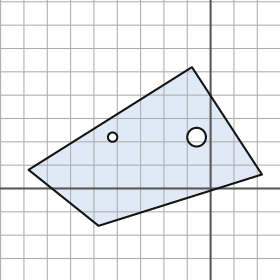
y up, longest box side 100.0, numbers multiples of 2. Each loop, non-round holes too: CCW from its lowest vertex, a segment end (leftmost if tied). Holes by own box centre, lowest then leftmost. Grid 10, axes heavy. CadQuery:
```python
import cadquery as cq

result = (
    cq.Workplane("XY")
    .moveTo(-48.0, -16.0)
    .lineTo(22.0, 6.0)
    .lineTo(-8.0, 52.0)
    .lineTo(-78.0, 8.0)
    .close()
    .moveTo(-42.0, 22.0)
    .circle(2.0)
    .moveTo(-6.0, 22.0)
    .circle(4.0)
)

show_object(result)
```